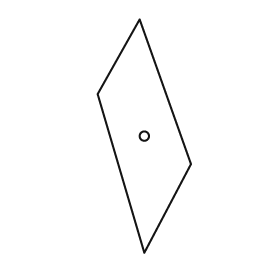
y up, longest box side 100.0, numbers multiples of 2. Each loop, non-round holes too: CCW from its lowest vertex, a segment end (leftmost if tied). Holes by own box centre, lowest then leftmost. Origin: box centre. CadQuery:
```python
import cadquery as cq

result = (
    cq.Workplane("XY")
    .moveTo(0.0, -50.0)
    .lineTo(20.0, -12.0)
    .lineTo(-2.0, 50.0)
    .lineTo(-20.0, 18.0)
    .close()
    .moveTo(0.0, 0.0)
    .circle(2.0)
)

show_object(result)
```